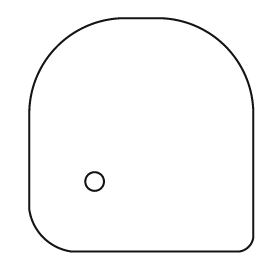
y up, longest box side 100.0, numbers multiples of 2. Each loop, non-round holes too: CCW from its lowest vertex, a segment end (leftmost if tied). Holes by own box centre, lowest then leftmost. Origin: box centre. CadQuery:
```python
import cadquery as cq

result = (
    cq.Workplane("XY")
    .moveTo(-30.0, -50.0)
    .lineTo(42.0, -50.0)
    .threePointArc((46.0, -48.0), (48.0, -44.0))
    .lineTo(48.0, 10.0)
    .threePointArc((36.0, 38.0), (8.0, 50.0))
    .lineTo(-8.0, 50.0)
    .threePointArc((-36.0, 38.0), (-48.0, 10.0))
    .lineTo(-48.0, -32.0)
    .threePointArc((-42.0, -44.0), (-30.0, -50.0))
    .close()
    .moveTo(-20.0, -20.0)
    .circle(4.0)
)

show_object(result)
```